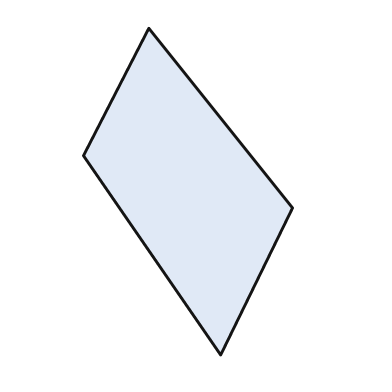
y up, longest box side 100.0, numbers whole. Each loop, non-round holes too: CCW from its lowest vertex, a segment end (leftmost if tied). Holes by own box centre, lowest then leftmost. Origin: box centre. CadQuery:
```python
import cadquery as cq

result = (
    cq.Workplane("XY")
    .moveTo(10.0, -50.0)
    .lineTo(32.0, -5.0)
    .lineTo(-12.0, 50.0)
    .lineTo(-32.0, 11.0)
    .close()
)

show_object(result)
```